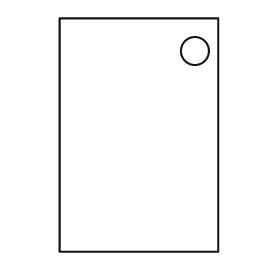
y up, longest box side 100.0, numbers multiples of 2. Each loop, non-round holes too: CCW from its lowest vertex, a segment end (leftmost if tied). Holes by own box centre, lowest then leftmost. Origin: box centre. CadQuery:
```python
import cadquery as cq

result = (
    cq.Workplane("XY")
    .moveTo(-34.0, -50.0)
    .lineTo(34.0, -50.0)
    .lineTo(34.0, 50.0)
    .lineTo(-34.0, 50.0)
    .close()
    .moveTo(24.0, 36.0)
    .circle(6.0)
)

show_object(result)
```